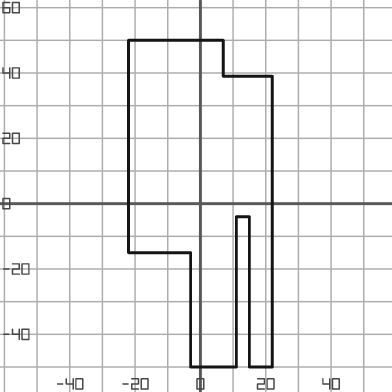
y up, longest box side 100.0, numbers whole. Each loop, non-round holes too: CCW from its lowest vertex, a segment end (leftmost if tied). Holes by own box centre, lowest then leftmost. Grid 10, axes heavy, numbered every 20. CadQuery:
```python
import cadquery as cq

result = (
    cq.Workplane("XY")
    .moveTo(-3.0, -50.0)
    .lineTo(11.0, -50.0)
    .lineTo(11.0, -4.0)
    .lineTo(15.0, -4.0)
    .lineTo(15.0, -50.0)
    .lineTo(22.0, -50.0)
    .lineTo(22.0, 39.0)
    .lineTo(7.0, 39.0)
    .lineTo(7.0, 50.0)
    .lineTo(-22.0, 50.0)
    .lineTo(-22.0, -15.0)
    .lineTo(-3.0, -15.0)
    .close()
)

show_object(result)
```